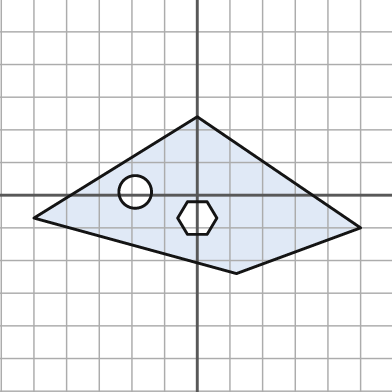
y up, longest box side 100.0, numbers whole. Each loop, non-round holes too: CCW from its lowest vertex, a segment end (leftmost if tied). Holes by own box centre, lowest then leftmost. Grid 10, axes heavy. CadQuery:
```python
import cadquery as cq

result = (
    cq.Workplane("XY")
    .moveTo(12.0, -24.0)
    .lineTo(50.0, -10.0)
    .lineTo(0.0, 24.0)
    .lineTo(-50.0, -7.0)
    .close()
    .moveTo(-3.0, -12.0)
    .lineTo(3.0, -12.0)
    .lineTo(6.0, -7.0)
    .lineTo(3.0, -2.0)
    .lineTo(-3.0, -2.0)
    .lineTo(-6.0, -7.0)
    .close()
    .moveTo(-19.0, 1.0)
    .circle(5.0)
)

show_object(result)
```